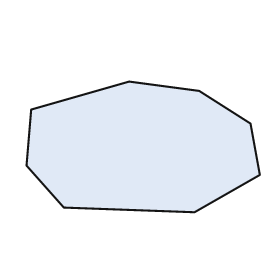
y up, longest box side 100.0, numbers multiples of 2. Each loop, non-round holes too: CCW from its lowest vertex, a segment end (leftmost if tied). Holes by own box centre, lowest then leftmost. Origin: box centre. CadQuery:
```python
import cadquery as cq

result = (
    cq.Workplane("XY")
    .moveTo(22.0, -28.0)
    .lineTo(50.0, -12.0)
    .lineTo(46.0, 10.0)
    .lineTo(24.0, 24.0)
    .lineTo(-6.0, 28.0)
    .lineTo(-48.0, 16.0)
    .lineTo(-50.0, -8.0)
    .lineTo(-34.0, -26.0)
    .close()
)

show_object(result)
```